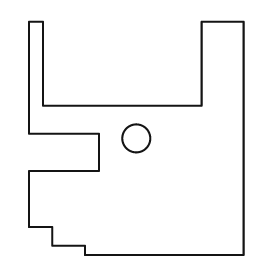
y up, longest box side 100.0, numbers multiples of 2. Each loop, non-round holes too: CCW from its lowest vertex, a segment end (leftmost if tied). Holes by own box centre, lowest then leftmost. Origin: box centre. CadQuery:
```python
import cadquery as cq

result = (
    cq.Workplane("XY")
    .moveTo(-22.0, -50.0)
    .lineTo(46.0, -50.0)
    .lineTo(46.0, 50.0)
    .lineTo(28.0, 50.0)
    .lineTo(28.0, 14.0)
    .lineTo(-40.0, 14.0)
    .lineTo(-40.0, 50.0)
    .lineTo(-46.0, 50.0)
    .lineTo(-46.0, 2.0)
    .lineTo(-16.0, 2.0)
    .lineTo(-16.0, -14.0)
    .lineTo(-46.0, -14.0)
    .lineTo(-46.0, -38.0)
    .lineTo(-36.0, -38.0)
    .lineTo(-36.0, -46.0)
    .lineTo(-22.0, -46.0)
    .close()
    .moveTo(0.0, 0.0)
    .circle(6.0)
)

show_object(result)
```